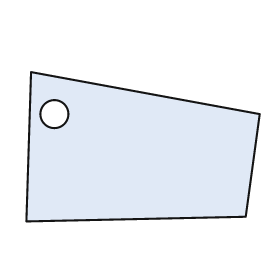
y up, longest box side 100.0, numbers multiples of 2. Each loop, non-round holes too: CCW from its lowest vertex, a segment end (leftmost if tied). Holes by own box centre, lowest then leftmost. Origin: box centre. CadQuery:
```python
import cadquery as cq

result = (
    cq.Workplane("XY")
    .moveTo(-50.0, -32.0)
    .lineTo(44.0, -30.0)
    .lineTo(50.0, 14.0)
    .lineTo(-48.0, 32.0)
    .close()
    .moveTo(-38.0, 14.0)
    .circle(6.0)
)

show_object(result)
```